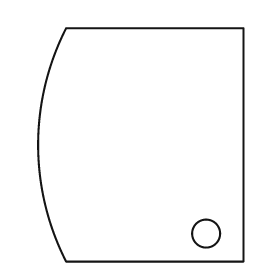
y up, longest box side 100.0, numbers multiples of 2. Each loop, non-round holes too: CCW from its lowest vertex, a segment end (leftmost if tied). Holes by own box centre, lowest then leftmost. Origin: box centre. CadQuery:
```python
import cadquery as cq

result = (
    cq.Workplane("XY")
    .moveTo(-32.0, -50.0)
    .lineTo(44.0, -50.0)
    .lineTo(44.0, 50.0)
    .lineTo(-32.0, 50.0)
    .threePointArc((-44.0, 0.0), (-32.0, -50.0))
    .close()
    .moveTo(28.0, -38.0)
    .circle(6.0)
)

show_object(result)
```